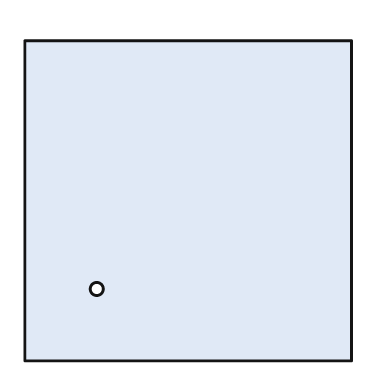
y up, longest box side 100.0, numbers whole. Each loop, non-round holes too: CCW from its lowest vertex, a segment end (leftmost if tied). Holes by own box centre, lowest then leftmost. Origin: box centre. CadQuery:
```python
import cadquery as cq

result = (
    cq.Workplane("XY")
    .moveTo(-50.0, -49.0)
    .lineTo(50.0, -49.0)
    .lineTo(50.0, 49.0)
    .lineTo(-50.0, 49.0)
    .close()
    .moveTo(-28.0, -27.0)
    .circle(2.0)
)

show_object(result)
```